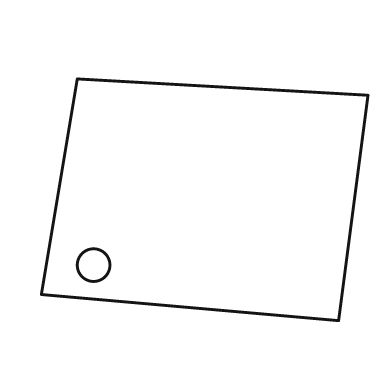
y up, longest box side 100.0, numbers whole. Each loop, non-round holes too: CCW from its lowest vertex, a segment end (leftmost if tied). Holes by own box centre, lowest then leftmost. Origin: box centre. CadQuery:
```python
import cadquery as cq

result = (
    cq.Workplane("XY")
    .moveTo(41.0, -37.0)
    .lineTo(50.0, 32.0)
    .lineTo(-39.0, 37.0)
    .lineTo(-50.0, -29.0)
    .close()
    .moveTo(-34.0, -20.0)
    .circle(5.0)
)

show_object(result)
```